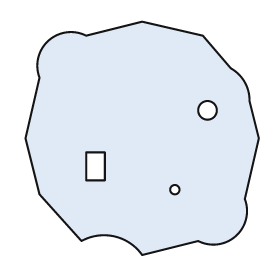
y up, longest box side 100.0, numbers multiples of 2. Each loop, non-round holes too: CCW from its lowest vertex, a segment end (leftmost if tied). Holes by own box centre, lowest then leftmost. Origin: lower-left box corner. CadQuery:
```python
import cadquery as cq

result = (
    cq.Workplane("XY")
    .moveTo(50.0, 0.0)
    .lineTo(74.0, 6.0)
    .threePointArc((90.0, 8.0), (94.0, 24.0))
    .lineTo(100.0, 50.0)
    .lineTo(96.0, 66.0)
    .threePointArc((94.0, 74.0), (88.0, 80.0))
    .lineTo(76.0, 94.0)
    .lineTo(50.0, 100.0)
    .lineTo(26.0, 94.0)
    .threePointArc((10.0, 92.0), (6.0, 76.0))
    .lineTo(0.0, 50.0)
    .lineTo(6.0, 26.0)
    .lineTo(24.0, 6.0)
    .threePointArc((38.0, 8.0), (50.0, 0.0))
    .close()
    .moveTo(64.0, 28.0)
    .circle(2.0)
    .moveTo(26.0, 32.0)
    .lineTo(34.0, 32.0)
    .lineTo(34.0, 44.0)
    .lineTo(26.0, 44.0)
    .close()
    .moveTo(78.0, 62.0)
    .circle(4.0)
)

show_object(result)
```